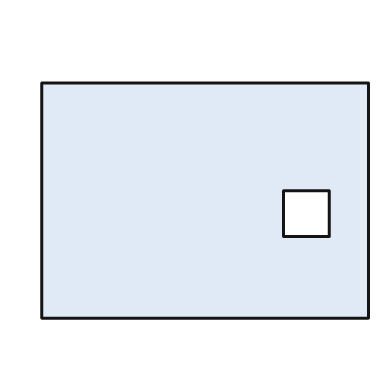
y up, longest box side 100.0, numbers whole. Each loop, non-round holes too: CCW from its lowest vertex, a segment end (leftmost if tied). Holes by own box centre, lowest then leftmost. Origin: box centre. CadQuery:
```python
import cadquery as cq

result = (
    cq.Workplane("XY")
    .moveTo(-50.0, -36.0)
    .lineTo(50.0, -36.0)
    .lineTo(50.0, 36.0)
    .lineTo(-50.0, 36.0)
    .close()
    .moveTo(24.0, -11.0)
    .lineTo(38.0, -11.0)
    .lineTo(38.0, 3.0)
    .lineTo(24.0, 3.0)
    .close()
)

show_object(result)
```